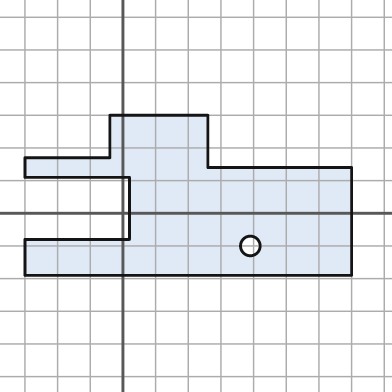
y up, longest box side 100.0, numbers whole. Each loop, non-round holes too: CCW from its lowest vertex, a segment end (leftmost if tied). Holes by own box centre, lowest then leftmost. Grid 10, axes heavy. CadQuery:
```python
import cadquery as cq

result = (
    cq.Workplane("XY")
    .moveTo(-30.0, -19.0)
    .lineTo(70.0, -19.0)
    .lineTo(70.0, 14.0)
    .lineTo(26.0, 14.0)
    .lineTo(26.0, 30.0)
    .lineTo(-4.0, 30.0)
    .lineTo(-4.0, 17.0)
    .lineTo(-30.0, 17.0)
    .lineTo(-30.0, 11.0)
    .lineTo(2.0, 11.0)
    .lineTo(2.0, -8.0)
    .lineTo(-30.0, -8.0)
    .close()
    .moveTo(39.0, -10.0)
    .circle(3.0)
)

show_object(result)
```